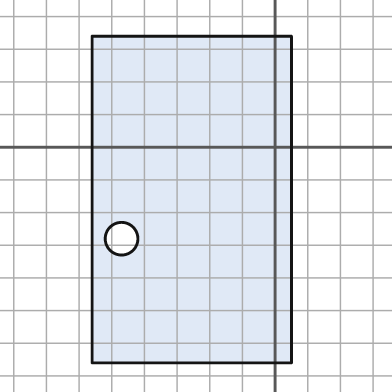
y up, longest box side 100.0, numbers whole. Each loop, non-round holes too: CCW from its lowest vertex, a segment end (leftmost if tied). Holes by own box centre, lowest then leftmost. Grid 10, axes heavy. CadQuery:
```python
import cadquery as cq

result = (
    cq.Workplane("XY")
    .moveTo(-56.0, -66.0)
    .lineTo(5.0, -66.0)
    .lineTo(5.0, 34.0)
    .lineTo(-56.0, 34.0)
    .close()
    .moveTo(-47.0, -28.0)
    .circle(5.0)
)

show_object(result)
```